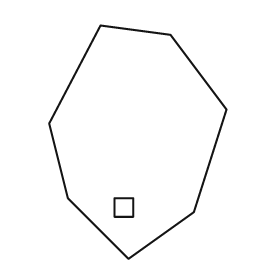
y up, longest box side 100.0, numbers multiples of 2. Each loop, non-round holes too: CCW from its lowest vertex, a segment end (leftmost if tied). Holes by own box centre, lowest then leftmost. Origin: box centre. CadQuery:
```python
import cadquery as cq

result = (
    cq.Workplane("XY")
    .moveTo(-4.0, -50.0)
    .lineTo(24.0, -30.0)
    .lineTo(38.0, 14.0)
    .lineTo(14.0, 46.0)
    .lineTo(-16.0, 50.0)
    .lineTo(-38.0, 8.0)
    .lineTo(-30.0, -24.0)
    .close()
    .moveTo(-10.0, -32.0)
    .lineTo(-2.0, -32.0)
    .lineTo(-2.0, -24.0)
    .lineTo(-10.0, -24.0)
    .close()
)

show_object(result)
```